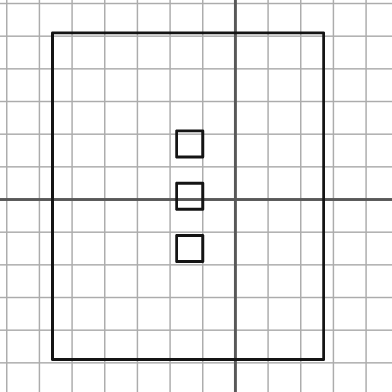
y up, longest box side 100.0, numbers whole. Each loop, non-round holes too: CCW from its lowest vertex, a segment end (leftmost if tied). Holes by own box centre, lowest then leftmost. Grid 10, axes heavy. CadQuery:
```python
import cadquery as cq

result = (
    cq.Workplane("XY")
    .moveTo(-56.0, -49.0)
    .lineTo(27.0, -49.0)
    .lineTo(27.0, 51.0)
    .lineTo(-56.0, 51.0)
    .close()
    .moveTo(-18.0, -19.0)
    .lineTo(-10.0, -19.0)
    .lineTo(-10.0, -11.0)
    .lineTo(-18.0, -11.0)
    .close()
    .moveTo(-18.0, -3.0)
    .lineTo(-10.0, -3.0)
    .lineTo(-10.0, 5.0)
    .lineTo(-18.0, 5.0)
    .close()
    .moveTo(-18.0, 13.0)
    .lineTo(-10.0, 13.0)
    .lineTo(-10.0, 21.0)
    .lineTo(-18.0, 21.0)
    .close()
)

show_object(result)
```